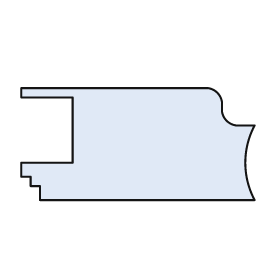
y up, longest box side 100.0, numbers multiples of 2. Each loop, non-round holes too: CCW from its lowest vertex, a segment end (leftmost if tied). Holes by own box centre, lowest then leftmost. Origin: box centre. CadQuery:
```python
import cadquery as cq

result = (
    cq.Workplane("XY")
    .moveTo(-42.0, -24.0)
    .lineTo(50.0, -24.0)
    .threePointArc((46.0, -8.0), (50.0, 8.0))
    .lineTo(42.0, 8.0)
    .threePointArc((38.0, 10.0), (36.0, 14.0))
    .lineTo(36.0, 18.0)
    .threePointArc((34.0, 22.0), (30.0, 24.0))
    .lineTo(-50.0, 24.0)
    .lineTo(-50.0, 20.0)
    .lineTo(-28.0, 20.0)
    .lineTo(-28.0, -8.0)
    .lineTo(-50.0, -8.0)
    .lineTo(-50.0, -14.0)
    .lineTo(-46.0, -14.0)
    .lineTo(-46.0, -18.0)
    .lineTo(-42.0, -18.0)
    .close()
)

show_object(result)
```